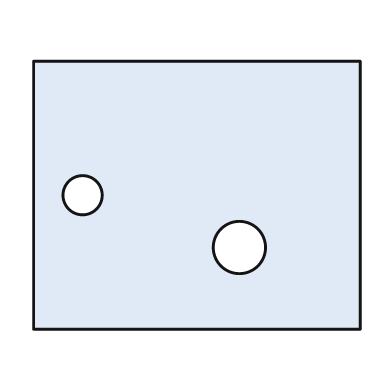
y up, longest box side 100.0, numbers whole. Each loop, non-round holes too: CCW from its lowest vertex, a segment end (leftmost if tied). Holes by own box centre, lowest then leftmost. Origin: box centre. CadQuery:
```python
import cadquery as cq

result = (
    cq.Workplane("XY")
    .moveTo(-50.0, -41.0)
    .lineTo(50.0, -41.0)
    .lineTo(50.0, 41.0)
    .lineTo(-50.0, 41.0)
    .close()
    .moveTo(13.0, -16.0)
    .circle(8.0)
    .moveTo(-35.0, 0.0)
    .circle(6.0)
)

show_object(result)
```